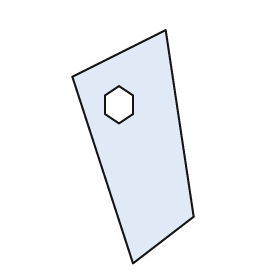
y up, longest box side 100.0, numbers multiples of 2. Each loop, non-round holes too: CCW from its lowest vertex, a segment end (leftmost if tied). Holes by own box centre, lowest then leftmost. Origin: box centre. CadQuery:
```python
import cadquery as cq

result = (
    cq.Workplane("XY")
    .moveTo(0.0, -50.0)
    .lineTo(26.0, -30.0)
    .lineTo(14.0, 50.0)
    .lineTo(-26.0, 30.0)
    .close()
    .moveTo(-6.0, 10.0)
    .lineTo(0.0, 14.0)
    .lineTo(0.0, 22.0)
    .lineTo(-6.0, 26.0)
    .lineTo(-12.0, 22.0)
    .lineTo(-12.0, 14.0)
    .close()
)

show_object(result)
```